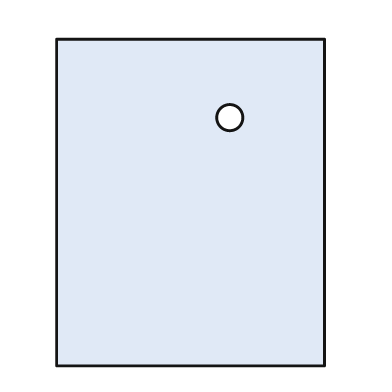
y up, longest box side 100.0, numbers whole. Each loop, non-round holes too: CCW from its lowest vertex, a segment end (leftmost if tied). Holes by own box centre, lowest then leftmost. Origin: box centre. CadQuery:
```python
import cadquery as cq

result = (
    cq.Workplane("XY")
    .moveTo(-41.0, -50.0)
    .lineTo(41.0, -50.0)
    .lineTo(41.0, 50.0)
    .lineTo(-41.0, 50.0)
    .close()
    .moveTo(12.0, 26.0)
    .circle(4.0)
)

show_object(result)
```